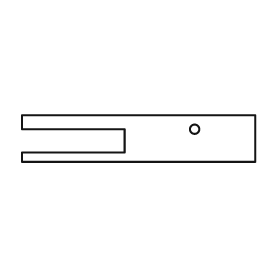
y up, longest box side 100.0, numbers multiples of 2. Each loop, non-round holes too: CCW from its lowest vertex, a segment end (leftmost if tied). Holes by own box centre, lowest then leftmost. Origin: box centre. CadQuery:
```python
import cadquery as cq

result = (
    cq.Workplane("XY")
    .moveTo(-50.0, -10.0)
    .lineTo(50.0, -10.0)
    .lineTo(50.0, 10.0)
    .lineTo(-50.0, 10.0)
    .lineTo(-50.0, 4.0)
    .lineTo(-6.0, 4.0)
    .lineTo(-6.0, -6.0)
    .lineTo(-50.0, -6.0)
    .close()
    .moveTo(24.0, 4.0)
    .circle(2.0)
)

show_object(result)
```